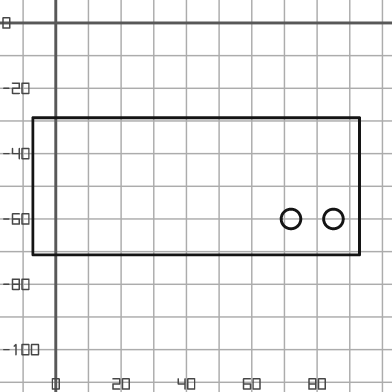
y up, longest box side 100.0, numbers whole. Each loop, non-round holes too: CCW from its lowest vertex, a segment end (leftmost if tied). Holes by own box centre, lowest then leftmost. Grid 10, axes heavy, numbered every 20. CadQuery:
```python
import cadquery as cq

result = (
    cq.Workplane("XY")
    .moveTo(-7.0, -71.0)
    .lineTo(93.0, -71.0)
    .lineTo(93.0, -29.0)
    .lineTo(-7.0, -29.0)
    .close()
    .moveTo(72.0, -60.0)
    .circle(3.0)
    .moveTo(85.0, -60.0)
    .circle(3.0)
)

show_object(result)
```